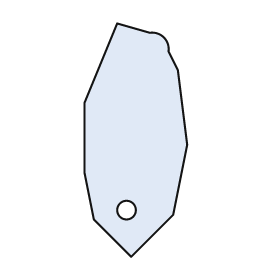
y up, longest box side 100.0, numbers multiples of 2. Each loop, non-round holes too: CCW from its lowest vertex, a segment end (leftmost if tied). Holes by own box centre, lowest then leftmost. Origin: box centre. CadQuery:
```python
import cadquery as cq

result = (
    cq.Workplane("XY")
    .moveTo(-2.0, -50.0)
    .lineTo(16.0, -32.0)
    .lineTo(22.0, -2.0)
    .lineTo(18.0, 30.0)
    .lineTo(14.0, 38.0)
    .threePointArc((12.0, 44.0), (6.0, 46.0))
    .lineTo(-8.0, 50.0)
    .lineTo(-22.0, 16.0)
    .lineTo(-22.0, -14.0)
    .lineTo(-18.0, -34.0)
    .close()
    .moveTo(-4.0, -30.0)
    .circle(4.0)
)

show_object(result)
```